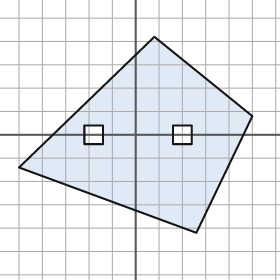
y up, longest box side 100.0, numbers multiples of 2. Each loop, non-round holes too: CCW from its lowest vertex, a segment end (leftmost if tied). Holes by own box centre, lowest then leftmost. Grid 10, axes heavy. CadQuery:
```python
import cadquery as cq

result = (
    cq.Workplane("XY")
    .moveTo(26.0, -42.0)
    .lineTo(50.0, 8.0)
    .lineTo(8.0, 42.0)
    .lineTo(-50.0, -14.0)
    .close()
    .moveTo(-22.0, -4.0)
    .lineTo(-14.0, -4.0)
    .lineTo(-14.0, 4.0)
    .lineTo(-22.0, 4.0)
    .close()
    .moveTo(16.0, -4.0)
    .lineTo(24.0, -4.0)
    .lineTo(24.0, 4.0)
    .lineTo(16.0, 4.0)
    .close()
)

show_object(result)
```